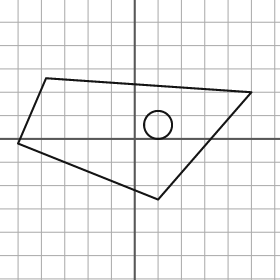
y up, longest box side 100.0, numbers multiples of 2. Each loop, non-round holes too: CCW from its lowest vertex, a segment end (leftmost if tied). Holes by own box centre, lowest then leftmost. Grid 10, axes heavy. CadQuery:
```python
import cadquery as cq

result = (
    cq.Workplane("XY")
    .moveTo(10.0, -26.0)
    .lineTo(50.0, 20.0)
    .lineTo(-38.0, 26.0)
    .lineTo(-50.0, -2.0)
    .close()
    .moveTo(10.0, 6.0)
    .circle(6.0)
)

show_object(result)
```